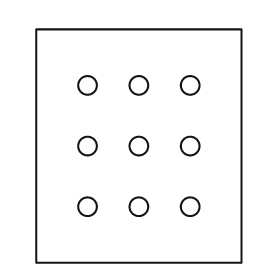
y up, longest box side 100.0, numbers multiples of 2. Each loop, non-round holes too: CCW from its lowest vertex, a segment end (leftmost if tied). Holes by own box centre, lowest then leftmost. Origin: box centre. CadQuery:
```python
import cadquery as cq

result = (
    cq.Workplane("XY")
    .moveTo(-44.0, -50.0)
    .lineTo(44.0, -50.0)
    .lineTo(44.0, 50.0)
    .lineTo(-44.0, 50.0)
    .close()
    .moveTo(-22.0, -26.0)
    .circle(4.0)
    .moveTo(0.0, -26.0)
    .circle(4.0)
    .moveTo(22.0, -26.0)
    .circle(4.0)
    .moveTo(-22.0, 0.0)
    .circle(4.0)
    .moveTo(0.0, 0.0)
    .circle(4.0)
    .moveTo(22.0, 0.0)
    .circle(4.0)
    .moveTo(-22.0, 26.0)
    .circle(4.0)
    .moveTo(0.0, 26.0)
    .circle(4.0)
    .moveTo(22.0, 26.0)
    .circle(4.0)
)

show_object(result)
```